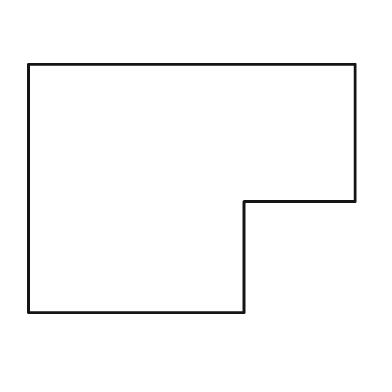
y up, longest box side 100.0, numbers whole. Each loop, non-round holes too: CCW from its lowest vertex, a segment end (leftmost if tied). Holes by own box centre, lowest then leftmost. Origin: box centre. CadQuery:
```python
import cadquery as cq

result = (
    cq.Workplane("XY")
    .moveTo(-50.0, -38.0)
    .lineTo(16.0, -38.0)
    .lineTo(16.0, -4.0)
    .lineTo(50.0, -4.0)
    .lineTo(50.0, 38.0)
    .lineTo(-50.0, 38.0)
    .close()
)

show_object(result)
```